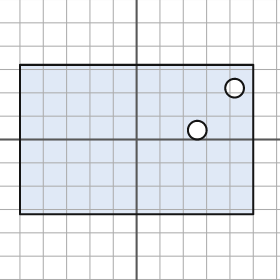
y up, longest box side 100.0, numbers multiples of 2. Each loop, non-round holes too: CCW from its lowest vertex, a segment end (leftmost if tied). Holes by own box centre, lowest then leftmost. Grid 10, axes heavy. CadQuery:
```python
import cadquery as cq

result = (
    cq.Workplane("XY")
    .moveTo(-50.0, -32.0)
    .lineTo(50.0, -32.0)
    .lineTo(50.0, 32.0)
    .lineTo(-50.0, 32.0)
    .close()
    .moveTo(26.0, 4.0)
    .circle(4.0)
    .moveTo(42.0, 22.0)
    .circle(4.0)
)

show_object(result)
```